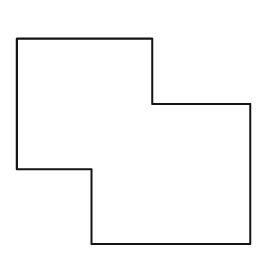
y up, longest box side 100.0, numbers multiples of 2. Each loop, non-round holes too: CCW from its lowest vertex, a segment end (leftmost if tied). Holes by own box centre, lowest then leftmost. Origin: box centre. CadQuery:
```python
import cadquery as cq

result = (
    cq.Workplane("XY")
    .moveTo(-18.0, -44.0)
    .lineTo(50.0, -44.0)
    .lineTo(50.0, 16.0)
    .lineTo(8.0, 16.0)
    .lineTo(8.0, 44.0)
    .lineTo(-50.0, 44.0)
    .lineTo(-50.0, -12.0)
    .lineTo(-18.0, -12.0)
    .close()
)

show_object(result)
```